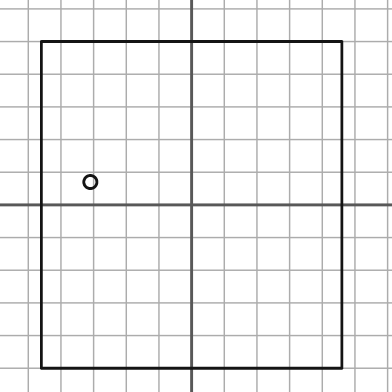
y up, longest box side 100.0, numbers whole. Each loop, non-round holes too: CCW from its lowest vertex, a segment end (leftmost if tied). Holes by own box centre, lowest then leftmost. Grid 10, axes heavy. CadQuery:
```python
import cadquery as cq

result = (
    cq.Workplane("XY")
    .moveTo(-46.0, -50.0)
    .lineTo(46.0, -50.0)
    .lineTo(46.0, 50.0)
    .lineTo(-46.0, 50.0)
    .close()
    .moveTo(-31.0, 7.0)
    .circle(2.0)
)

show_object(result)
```